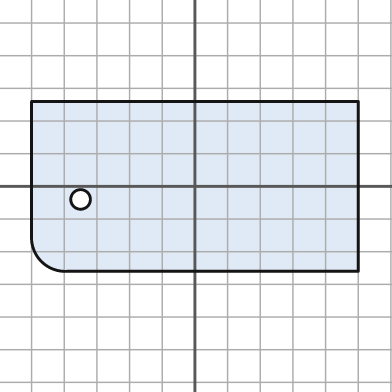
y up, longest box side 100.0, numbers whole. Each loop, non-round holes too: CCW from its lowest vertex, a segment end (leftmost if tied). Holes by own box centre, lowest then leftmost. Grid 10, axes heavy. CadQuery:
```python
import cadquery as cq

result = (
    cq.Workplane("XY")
    .moveTo(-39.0, -26.0)
    .lineTo(50.0, -26.0)
    .lineTo(50.0, 26.0)
    .lineTo(-50.0, 26.0)
    .lineTo(-50.0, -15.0)
    .threePointArc((-47.0, -23.0), (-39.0, -26.0))
    .close()
    .moveTo(-35.0, -4.0)
    .circle(3.0)
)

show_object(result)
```